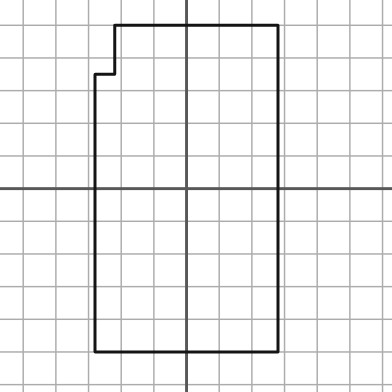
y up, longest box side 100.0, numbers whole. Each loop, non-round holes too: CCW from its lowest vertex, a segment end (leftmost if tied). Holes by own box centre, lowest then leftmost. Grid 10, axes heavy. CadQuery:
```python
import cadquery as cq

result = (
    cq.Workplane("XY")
    .moveTo(-28.0, -50.0)
    .lineTo(28.0, -50.0)
    .lineTo(28.0, 50.0)
    .lineTo(-22.0, 50.0)
    .lineTo(-22.0, 35.0)
    .lineTo(-28.0, 35.0)
    .close()
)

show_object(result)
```